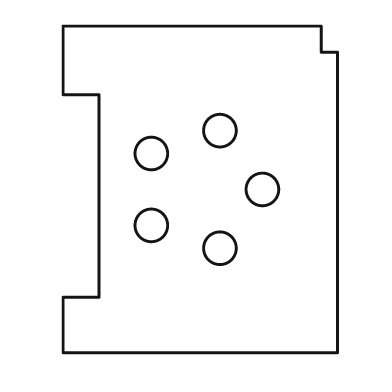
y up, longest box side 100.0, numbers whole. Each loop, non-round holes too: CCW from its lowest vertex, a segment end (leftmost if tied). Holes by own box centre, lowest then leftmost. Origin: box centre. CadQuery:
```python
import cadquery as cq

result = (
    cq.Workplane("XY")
    .moveTo(-42.0, -50.0)
    .lineTo(42.0, -50.0)
    .lineTo(42.0, 42.0)
    .lineTo(37.0, 42.0)
    .lineTo(37.0, 50.0)
    .lineTo(-42.0, 50.0)
    .lineTo(-42.0, 29.0)
    .lineTo(-31.0, 29.0)
    .lineTo(-31.0, -33.0)
    .lineTo(-42.0, -33.0)
    .close()
    .moveTo(6.0, -18.0)
    .circle(5.0)
    .moveTo(-15.0, -11.0)
    .circle(5.0)
    .moveTo(19.0, 0.0)
    .circle(5.0)
    .moveTo(-15.0, 11.0)
    .circle(5.0)
    .moveTo(6.0, 18.0)
    .circle(5.0)
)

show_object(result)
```